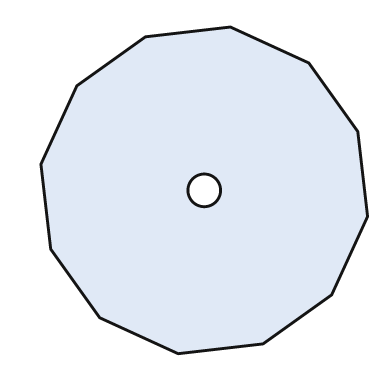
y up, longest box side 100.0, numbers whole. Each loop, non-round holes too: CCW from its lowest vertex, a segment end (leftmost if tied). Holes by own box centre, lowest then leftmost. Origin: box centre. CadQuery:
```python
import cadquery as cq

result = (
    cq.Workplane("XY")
    .moveTo(-8.0, -50.0)
    .lineTo(18.0, -47.0)
    .lineTo(39.0, -32.0)
    .lineTo(50.0, -8.0)
    .lineTo(47.0, 18.0)
    .lineTo(32.0, 39.0)
    .lineTo(8.0, 50.0)
    .lineTo(-18.0, 47.0)
    .lineTo(-39.0, 32.0)
    .lineTo(-50.0, 8.0)
    .lineTo(-47.0, -18.0)
    .lineTo(-32.0, -39.0)
    .close()
    .moveTo(0.0, 0.0)
    .circle(5.0)
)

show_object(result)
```